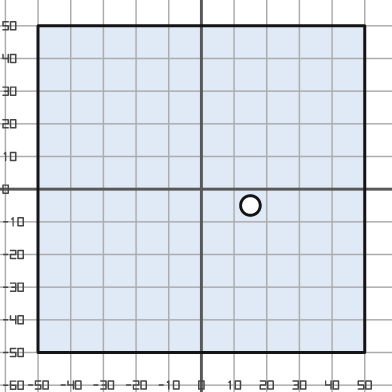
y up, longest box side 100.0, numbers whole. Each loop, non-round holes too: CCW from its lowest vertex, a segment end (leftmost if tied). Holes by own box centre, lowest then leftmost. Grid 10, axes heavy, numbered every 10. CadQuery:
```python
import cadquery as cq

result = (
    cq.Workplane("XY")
    .moveTo(-50.0, -50.0)
    .lineTo(50.0, -50.0)
    .lineTo(50.0, 50.0)
    .lineTo(-50.0, 50.0)
    .close()
    .moveTo(15.0, -5.0)
    .circle(3.0)
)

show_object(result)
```